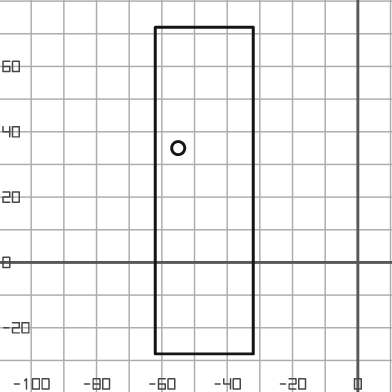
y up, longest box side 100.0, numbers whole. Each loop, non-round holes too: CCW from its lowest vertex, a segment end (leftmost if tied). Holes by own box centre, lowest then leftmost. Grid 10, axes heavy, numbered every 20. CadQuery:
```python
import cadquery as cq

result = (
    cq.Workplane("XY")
    .moveTo(-62.0, -28.0)
    .lineTo(-32.0, -28.0)
    .lineTo(-32.0, 72.0)
    .lineTo(-62.0, 72.0)
    .close()
    .moveTo(-55.0, 35.0)
    .circle(2.0)
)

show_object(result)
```